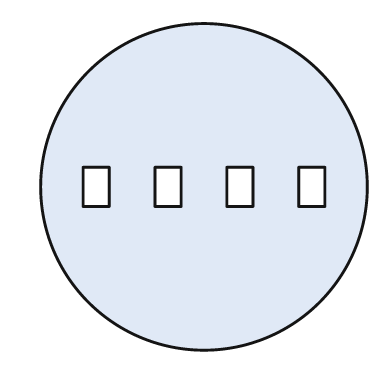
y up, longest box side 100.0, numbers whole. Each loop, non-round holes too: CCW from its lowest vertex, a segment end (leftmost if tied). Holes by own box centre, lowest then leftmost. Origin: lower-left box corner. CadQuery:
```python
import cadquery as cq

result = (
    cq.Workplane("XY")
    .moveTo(50.0, 50.0)
    .circle(50.0)
    .moveTo(13.0, 44.0)
    .lineTo(21.0, 44.0)
    .lineTo(21.0, 56.0)
    .lineTo(13.0, 56.0)
    .close()
    .moveTo(35.0, 44.0)
    .lineTo(43.0, 44.0)
    .lineTo(43.0, 56.0)
    .lineTo(35.0, 56.0)
    .close()
    .moveTo(57.0, 44.0)
    .lineTo(65.0, 44.0)
    .lineTo(65.0, 56.0)
    .lineTo(57.0, 56.0)
    .close()
    .moveTo(79.0, 44.0)
    .lineTo(87.0, 44.0)
    .lineTo(87.0, 56.0)
    .lineTo(79.0, 56.0)
    .close()
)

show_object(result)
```